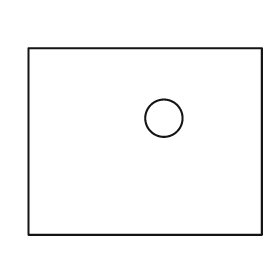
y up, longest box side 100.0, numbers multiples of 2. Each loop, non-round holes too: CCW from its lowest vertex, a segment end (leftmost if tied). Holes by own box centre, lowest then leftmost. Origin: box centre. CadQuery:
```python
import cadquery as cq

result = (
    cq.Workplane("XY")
    .moveTo(-50.0, -40.0)
    .lineTo(50.0, -40.0)
    .lineTo(50.0, 40.0)
    .lineTo(-50.0, 40.0)
    .close()
    .moveTo(8.0, 10.0)
    .circle(8.0)
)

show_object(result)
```